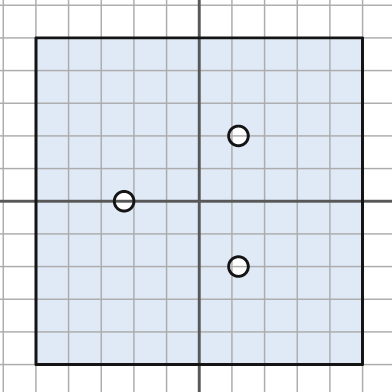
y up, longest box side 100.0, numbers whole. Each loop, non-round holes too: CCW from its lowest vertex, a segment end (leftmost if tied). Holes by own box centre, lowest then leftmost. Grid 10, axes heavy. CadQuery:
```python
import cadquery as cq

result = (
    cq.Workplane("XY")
    .moveTo(-50.0, -50.0)
    .lineTo(50.0, -50.0)
    .lineTo(50.0, 50.0)
    .lineTo(-50.0, 50.0)
    .close()
    .moveTo(12.0, -20.0)
    .circle(3.0)
    .moveTo(-23.0, 0.0)
    .circle(3.0)
    .moveTo(12.0, 20.0)
    .circle(3.0)
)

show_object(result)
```